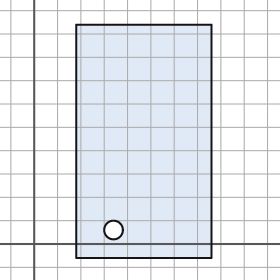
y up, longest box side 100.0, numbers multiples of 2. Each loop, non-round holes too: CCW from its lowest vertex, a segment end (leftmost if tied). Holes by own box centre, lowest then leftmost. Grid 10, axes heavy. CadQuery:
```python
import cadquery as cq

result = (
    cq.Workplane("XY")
    .moveTo(18.0, -6.0)
    .lineTo(76.0, -6.0)
    .lineTo(76.0, 94.0)
    .lineTo(18.0, 94.0)
    .close()
    .moveTo(34.0, 6.0)
    .circle(4.0)
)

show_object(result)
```